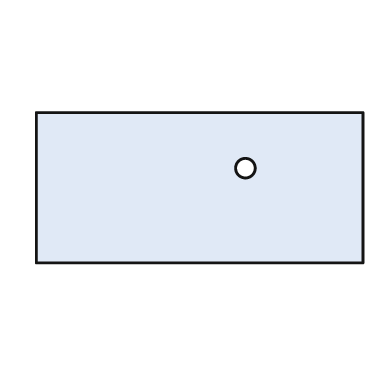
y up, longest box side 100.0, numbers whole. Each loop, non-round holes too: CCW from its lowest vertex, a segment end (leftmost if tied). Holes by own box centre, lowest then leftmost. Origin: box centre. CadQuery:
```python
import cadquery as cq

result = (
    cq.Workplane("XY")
    .moveTo(-50.0, -23.0)
    .lineTo(50.0, -23.0)
    .lineTo(50.0, 23.0)
    .lineTo(-50.0, 23.0)
    .close()
    .moveTo(14.0, 6.0)
    .circle(3.0)
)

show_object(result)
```